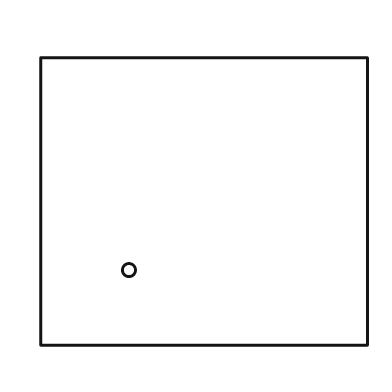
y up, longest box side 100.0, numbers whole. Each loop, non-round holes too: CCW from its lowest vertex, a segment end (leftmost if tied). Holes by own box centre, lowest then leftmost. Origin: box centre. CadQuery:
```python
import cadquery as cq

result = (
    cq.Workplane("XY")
    .moveTo(-50.0, -44.0)
    .lineTo(50.0, -44.0)
    .lineTo(50.0, 44.0)
    .lineTo(-50.0, 44.0)
    .close()
    .moveTo(-23.0, -21.0)
    .circle(2.0)
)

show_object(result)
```